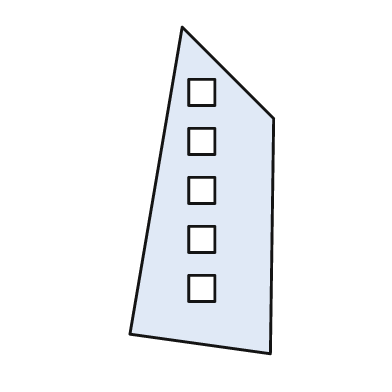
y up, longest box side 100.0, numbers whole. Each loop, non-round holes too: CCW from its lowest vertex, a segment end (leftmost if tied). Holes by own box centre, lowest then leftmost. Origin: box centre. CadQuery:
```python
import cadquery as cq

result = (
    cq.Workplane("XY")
    .moveTo(21.0, -50.0)
    .lineTo(22.0, 22.0)
    .lineTo(-6.0, 50.0)
    .lineTo(-22.0, -44.0)
    .close()
    .moveTo(-4.0, -34.0)
    .lineTo(4.0, -34.0)
    .lineTo(4.0, -26.0)
    .lineTo(-4.0, -26.0)
    .close()
    .moveTo(-4.0, -19.0)
    .lineTo(4.0, -19.0)
    .lineTo(4.0, -11.0)
    .lineTo(-4.0, -11.0)
    .close()
    .moveTo(-4.0, -4.0)
    .lineTo(4.0, -4.0)
    .lineTo(4.0, 4.0)
    .lineTo(-4.0, 4.0)
    .close()
    .moveTo(-4.0, 11.0)
    .lineTo(4.0, 11.0)
    .lineTo(4.0, 19.0)
    .lineTo(-4.0, 19.0)
    .close()
    .moveTo(-4.0, 26.0)
    .lineTo(4.0, 26.0)
    .lineTo(4.0, 34.0)
    .lineTo(-4.0, 34.0)
    .close()
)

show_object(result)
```